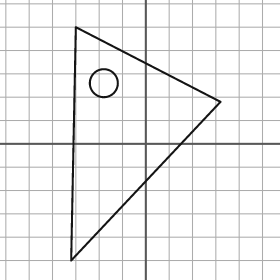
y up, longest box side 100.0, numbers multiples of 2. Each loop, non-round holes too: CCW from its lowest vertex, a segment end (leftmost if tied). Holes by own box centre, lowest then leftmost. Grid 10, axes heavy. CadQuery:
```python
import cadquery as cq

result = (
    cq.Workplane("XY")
    .moveTo(-32.0, -50.0)
    .lineTo(32.0, 18.0)
    .lineTo(-30.0, 50.0)
    .close()
    .moveTo(-18.0, 26.0)
    .circle(6.0)
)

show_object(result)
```